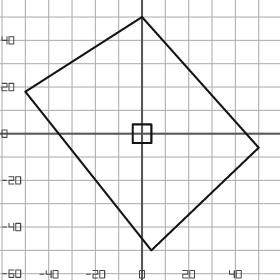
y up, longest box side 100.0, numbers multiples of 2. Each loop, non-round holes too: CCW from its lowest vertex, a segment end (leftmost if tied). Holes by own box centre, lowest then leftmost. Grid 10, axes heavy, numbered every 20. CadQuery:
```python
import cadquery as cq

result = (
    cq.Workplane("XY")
    .moveTo(4.0, -50.0)
    .lineTo(50.0, -6.0)
    .lineTo(0.0, 50.0)
    .lineTo(-50.0, 18.0)
    .close()
    .moveTo(-4.0, -4.0)
    .lineTo(4.0, -4.0)
    .lineTo(4.0, 4.0)
    .lineTo(-4.0, 4.0)
    .close()
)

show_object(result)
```